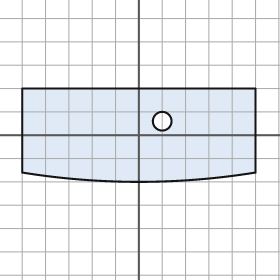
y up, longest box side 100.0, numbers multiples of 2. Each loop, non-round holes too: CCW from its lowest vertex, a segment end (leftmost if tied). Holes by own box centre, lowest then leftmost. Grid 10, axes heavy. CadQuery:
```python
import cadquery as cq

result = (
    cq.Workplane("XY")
    .moveTo(-50.0, -16.0)
    .threePointArc((0.0, -20.0), (50.0, -16.0))
    .lineTo(50.0, 20.0)
    .lineTo(-50.0, 20.0)
    .close()
    .moveTo(10.0, 6.0)
    .circle(4.0)
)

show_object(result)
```